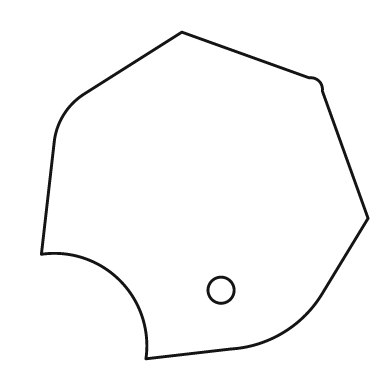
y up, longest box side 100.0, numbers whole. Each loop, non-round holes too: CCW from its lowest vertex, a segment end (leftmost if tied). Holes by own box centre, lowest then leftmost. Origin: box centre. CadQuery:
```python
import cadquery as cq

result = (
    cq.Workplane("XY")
    .moveTo(-18.0, -50.0)
    .lineTo(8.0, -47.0)
    .threePointArc((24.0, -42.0), (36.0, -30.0))
    .lineTo(50.0, -7.0)
    .lineTo(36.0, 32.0)
    .threePointArc((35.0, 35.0), (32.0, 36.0))
    .lineTo(-7.0, 50.0)
    .lineTo(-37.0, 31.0)
    .threePointArc((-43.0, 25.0), (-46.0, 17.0))
    .lineTo(-50.0, -18.0)
    .threePointArc((-26.0, -26.0), (-18.0, -50.0))
    .close()
    .moveTo(5.0, -29.0)
    .circle(4.0)
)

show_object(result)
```